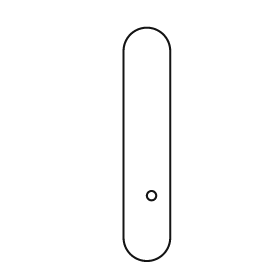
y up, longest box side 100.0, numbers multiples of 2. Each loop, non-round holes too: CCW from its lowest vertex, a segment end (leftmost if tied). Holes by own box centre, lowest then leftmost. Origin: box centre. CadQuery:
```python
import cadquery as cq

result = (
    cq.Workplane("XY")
    .moveTo(-10.0, -40.0)
    .threePointArc((0.0, -50.0), (10.0, -40.0))
    .lineTo(10.0, 40.0)
    .threePointArc((0.0, 50.0), (-10.0, 40.0))
    .close()
    .moveTo(2.0, -22.0)
    .circle(2.0)
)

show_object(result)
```